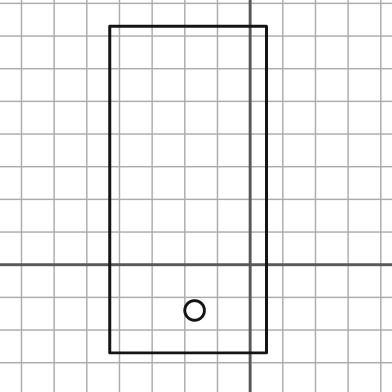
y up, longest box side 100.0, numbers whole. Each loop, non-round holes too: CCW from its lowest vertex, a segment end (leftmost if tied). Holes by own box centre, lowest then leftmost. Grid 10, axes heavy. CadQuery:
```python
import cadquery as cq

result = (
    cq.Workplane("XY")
    .moveTo(-43.0, -27.0)
    .lineTo(5.0, -27.0)
    .lineTo(5.0, 73.0)
    .lineTo(-43.0, 73.0)
    .close()
    .moveTo(-17.0, -14.0)
    .circle(3.0)
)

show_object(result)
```